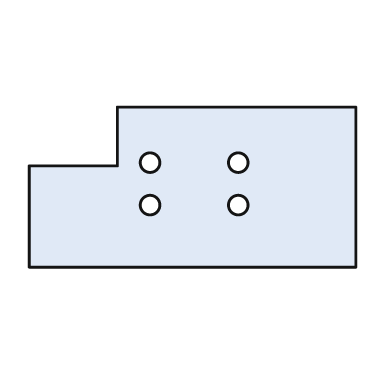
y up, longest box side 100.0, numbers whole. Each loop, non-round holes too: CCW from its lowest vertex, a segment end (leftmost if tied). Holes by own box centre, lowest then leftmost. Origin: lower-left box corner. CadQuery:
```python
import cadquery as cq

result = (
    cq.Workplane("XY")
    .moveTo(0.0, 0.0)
    .lineTo(100.0, 0.0)
    .lineTo(100.0, 49.0)
    .lineTo(27.0, 49.0)
    .lineTo(27.0, 31.0)
    .lineTo(0.0, 31.0)
    .close()
    .moveTo(37.0, 19.0)
    .circle(3.0)
    .moveTo(64.0, 19.0)
    .circle(3.0)
    .moveTo(37.0, 32.0)
    .circle(3.0)
    .moveTo(64.0, 32.0)
    .circle(3.0)
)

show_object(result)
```